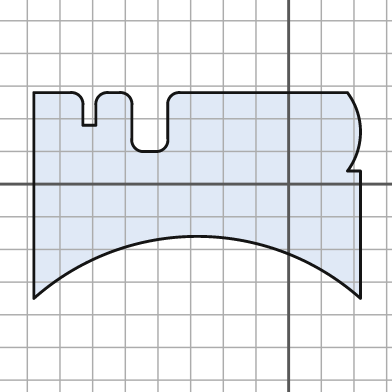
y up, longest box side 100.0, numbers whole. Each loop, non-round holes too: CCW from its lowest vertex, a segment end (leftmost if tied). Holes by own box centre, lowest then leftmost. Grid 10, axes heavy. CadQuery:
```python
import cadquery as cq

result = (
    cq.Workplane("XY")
    .moveTo(-78.0, -35.0)
    .threePointArc((-28.0, -16.0), (22.0, -35.0))
    .lineTo(22.0, 4.0)
    .lineTo(18.0, 4.0)
    .threePointArc((22.0, 16.0), (18.0, 28.0))
    .lineTo(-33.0, 28.0)
    .threePointArc((-36.0, 27.0), (-37.0, 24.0))
    .lineTo(-37.0, 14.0)
    .threePointArc((-38.0, 11.0), (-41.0, 10.0))
    .lineTo(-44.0, 10.0)
    .threePointArc((-47.0, 11.0), (-48.0, 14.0))
    .lineTo(-48.0, 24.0)
    .threePointArc((-49.0, 27.0), (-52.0, 28.0))
    .lineTo(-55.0, 28.0)
    .threePointArc((-58.0, 27.0), (-59.0, 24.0))
    .lineTo(-59.0, 18.0)
    .lineTo(-63.0, 18.0)
    .lineTo(-63.0, 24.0)
    .threePointArc((-64.0, 27.0), (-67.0, 28.0))
    .lineTo(-78.0, 28.0)
    .close()
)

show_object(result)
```